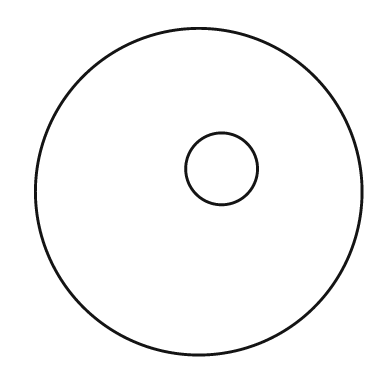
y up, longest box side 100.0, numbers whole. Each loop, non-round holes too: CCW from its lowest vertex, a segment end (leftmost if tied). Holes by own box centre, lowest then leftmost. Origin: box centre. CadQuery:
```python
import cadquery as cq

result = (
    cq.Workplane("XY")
    .moveTo(0.0, 0.0)
    .circle(50.0)
    .moveTo(7.0, 7.0)
    .circle(11.0)
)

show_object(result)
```